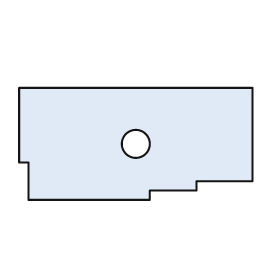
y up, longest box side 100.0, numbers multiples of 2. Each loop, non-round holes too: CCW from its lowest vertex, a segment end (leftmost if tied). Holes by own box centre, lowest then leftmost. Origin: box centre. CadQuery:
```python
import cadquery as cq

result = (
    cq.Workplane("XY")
    .moveTo(-46.0, -24.0)
    .lineTo(6.0, -24.0)
    .lineTo(6.0, -20.0)
    .lineTo(26.0, -20.0)
    .lineTo(26.0, -16.0)
    .lineTo(50.0, -16.0)
    .lineTo(50.0, 24.0)
    .lineTo(-50.0, 24.0)
    .lineTo(-50.0, -8.0)
    .lineTo(-46.0, -8.0)
    .close()
    .moveTo(0.0, 0.0)
    .circle(6.0)
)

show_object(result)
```